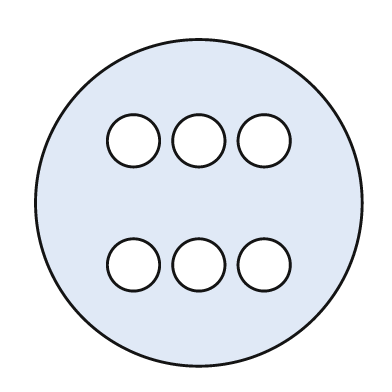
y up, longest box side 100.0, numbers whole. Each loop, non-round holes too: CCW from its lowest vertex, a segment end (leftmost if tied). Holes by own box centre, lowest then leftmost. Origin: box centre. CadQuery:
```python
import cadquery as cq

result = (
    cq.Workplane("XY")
    .moveTo(0.0, 0.0)
    .circle(50.0)
    .moveTo(-20.0, -19.0)
    .circle(8.0)
    .moveTo(0.0, -19.0)
    .circle(8.0)
    .moveTo(20.0, -19.0)
    .circle(8.0)
    .moveTo(-20.0, 19.0)
    .circle(8.0)
    .moveTo(0.0, 19.0)
    .circle(8.0)
    .moveTo(20.0, 19.0)
    .circle(8.0)
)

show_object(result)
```